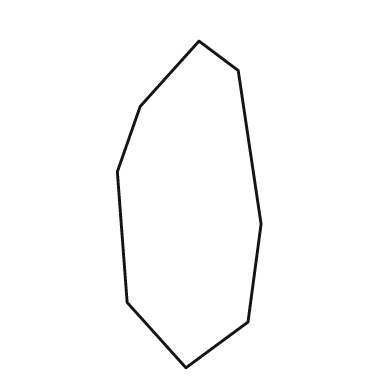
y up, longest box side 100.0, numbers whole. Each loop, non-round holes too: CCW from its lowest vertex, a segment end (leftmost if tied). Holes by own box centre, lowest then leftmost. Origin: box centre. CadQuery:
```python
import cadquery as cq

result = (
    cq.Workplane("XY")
    .moveTo(-1.0, -50.0)
    .lineTo(18.0, -36.0)
    .lineTo(22.0, -6.0)
    .lineTo(15.0, 41.0)
    .lineTo(3.0, 50.0)
    .lineTo(-15.0, 30.0)
    .lineTo(-22.0, 10.0)
    .lineTo(-19.0, -30.0)
    .close()
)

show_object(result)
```